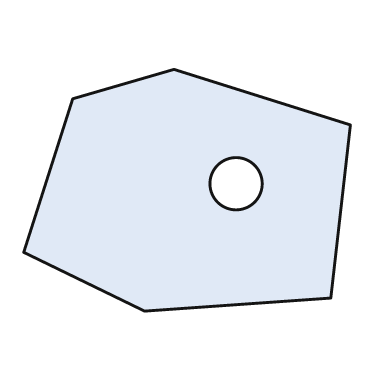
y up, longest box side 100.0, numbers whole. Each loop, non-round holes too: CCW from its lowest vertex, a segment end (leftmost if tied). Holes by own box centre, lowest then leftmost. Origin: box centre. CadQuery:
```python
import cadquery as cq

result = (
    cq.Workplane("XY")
    .moveTo(-13.0, -37.0)
    .lineTo(44.0, -33.0)
    .lineTo(50.0, 20.0)
    .lineTo(-4.0, 37.0)
    .lineTo(-35.0, 28.0)
    .lineTo(-50.0, -19.0)
    .close()
    .moveTo(15.0, 2.0)
    .circle(8.0)
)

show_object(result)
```